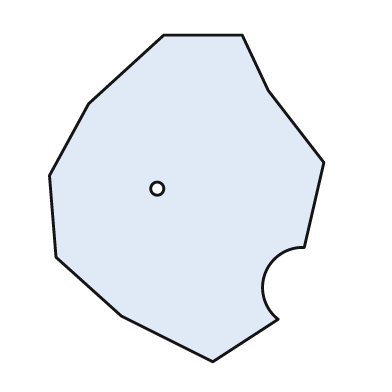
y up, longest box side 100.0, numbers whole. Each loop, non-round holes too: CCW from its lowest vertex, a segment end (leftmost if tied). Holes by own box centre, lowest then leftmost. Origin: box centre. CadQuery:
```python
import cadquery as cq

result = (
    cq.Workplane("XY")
    .moveTo(8.0, -50.0)
    .lineTo(28.0, -37.0)
    .threePointArc((24.0, -23.0), (36.0, -15.0))
    .lineTo(42.0, 11.0)
    .lineTo(25.0, 33.0)
    .lineTo(17.0, 50.0)
    .lineTo(-7.0, 50.0)
    .lineTo(-30.0, 29.0)
    .lineTo(-42.0, 7.0)
    .lineTo(-40.0, -18.0)
    .lineTo(-20.0, -36.0)
    .close()
    .moveTo(-9.0, 3.0)
    .circle(2.0)
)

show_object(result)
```